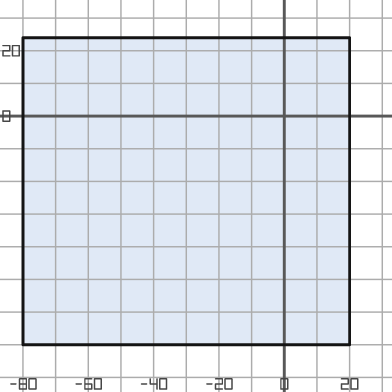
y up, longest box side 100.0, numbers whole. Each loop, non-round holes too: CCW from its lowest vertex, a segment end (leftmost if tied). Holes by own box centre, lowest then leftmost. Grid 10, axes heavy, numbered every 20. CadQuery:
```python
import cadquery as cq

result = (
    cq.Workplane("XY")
    .moveTo(-80.0, -70.0)
    .lineTo(20.0, -70.0)
    .lineTo(20.0, 24.0)
    .lineTo(-80.0, 24.0)
    .close()
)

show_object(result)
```